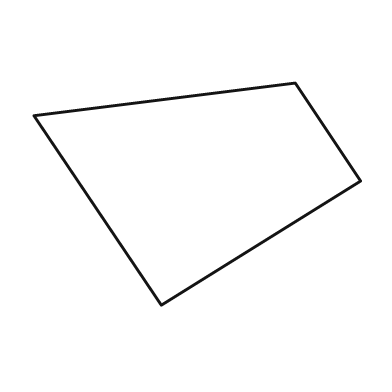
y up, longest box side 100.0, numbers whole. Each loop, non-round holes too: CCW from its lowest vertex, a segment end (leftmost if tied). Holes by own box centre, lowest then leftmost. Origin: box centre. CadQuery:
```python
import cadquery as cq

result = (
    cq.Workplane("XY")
    .moveTo(-11.0, -34.0)
    .lineTo(50.0, 4.0)
    .lineTo(30.0, 34.0)
    .lineTo(-50.0, 24.0)
    .close()
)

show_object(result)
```